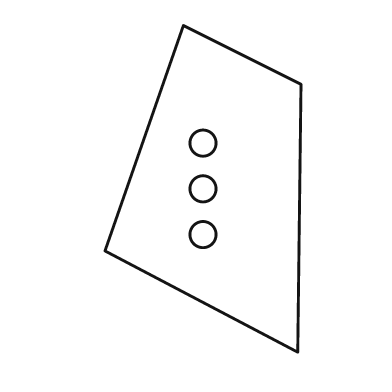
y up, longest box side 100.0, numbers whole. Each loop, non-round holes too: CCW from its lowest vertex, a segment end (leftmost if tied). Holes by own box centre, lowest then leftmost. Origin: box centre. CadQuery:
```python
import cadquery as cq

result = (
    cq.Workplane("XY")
    .moveTo(29.0, -50.0)
    .lineTo(30.0, 32.0)
    .lineTo(-6.0, 50.0)
    .lineTo(-30.0, -19.0)
    .close()
    .moveTo(0.0, -14.0)
    .circle(4.0)
    .moveTo(0.0, 0.0)
    .circle(4.0)
    .moveTo(0.0, 14.0)
    .circle(4.0)
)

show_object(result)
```